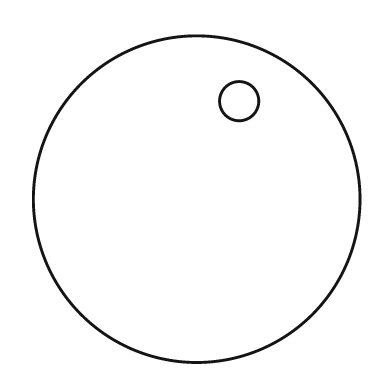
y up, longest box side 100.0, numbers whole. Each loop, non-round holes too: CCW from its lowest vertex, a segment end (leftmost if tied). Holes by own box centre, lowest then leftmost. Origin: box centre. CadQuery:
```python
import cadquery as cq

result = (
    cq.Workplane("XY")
    .moveTo(0.0, 0.0)
    .circle(50.0)
    .moveTo(13.0, 30.0)
    .circle(6.0)
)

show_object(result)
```